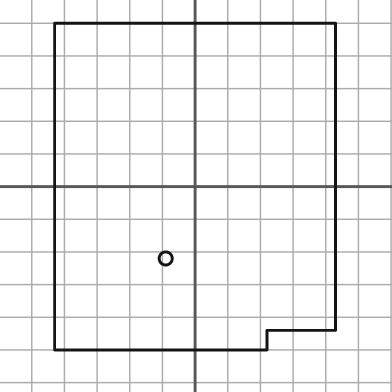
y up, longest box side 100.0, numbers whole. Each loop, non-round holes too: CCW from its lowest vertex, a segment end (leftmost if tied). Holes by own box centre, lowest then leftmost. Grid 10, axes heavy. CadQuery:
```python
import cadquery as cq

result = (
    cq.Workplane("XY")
    .moveTo(-43.0, -50.0)
    .lineTo(22.0, -50.0)
    .lineTo(22.0, -44.0)
    .lineTo(43.0, -44.0)
    .lineTo(43.0, 50.0)
    .lineTo(-43.0, 50.0)
    .close()
    .moveTo(-9.0, -22.0)
    .circle(2.0)
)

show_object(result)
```